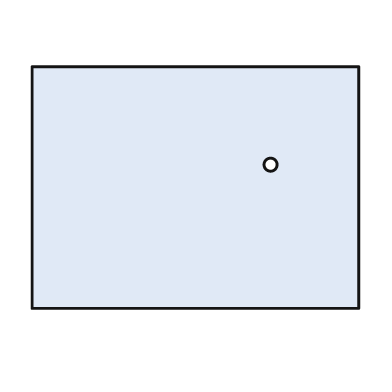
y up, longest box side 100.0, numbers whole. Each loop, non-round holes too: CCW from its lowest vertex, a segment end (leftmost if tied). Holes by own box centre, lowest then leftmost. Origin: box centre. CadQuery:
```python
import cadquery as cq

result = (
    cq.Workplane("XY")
    .moveTo(-50.0, -37.0)
    .lineTo(50.0, -37.0)
    .lineTo(50.0, 37.0)
    .lineTo(-50.0, 37.0)
    .close()
    .moveTo(23.0, 7.0)
    .circle(2.0)
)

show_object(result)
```